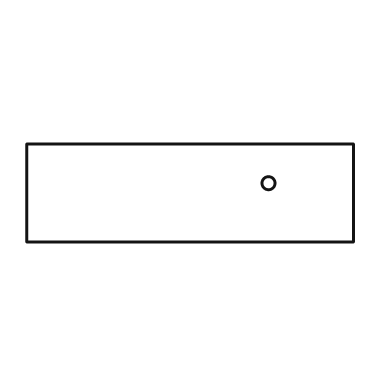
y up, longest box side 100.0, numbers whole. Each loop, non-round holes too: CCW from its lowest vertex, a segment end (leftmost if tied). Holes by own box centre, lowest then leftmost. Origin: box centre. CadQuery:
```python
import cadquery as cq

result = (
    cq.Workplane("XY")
    .moveTo(-50.0, -15.0)
    .lineTo(50.0, -15.0)
    .lineTo(50.0, 15.0)
    .lineTo(-50.0, 15.0)
    .close()
    .moveTo(24.0, 3.0)
    .circle(2.0)
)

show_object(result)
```